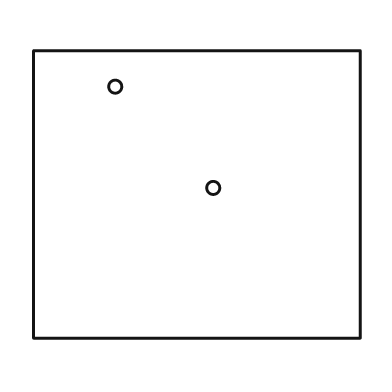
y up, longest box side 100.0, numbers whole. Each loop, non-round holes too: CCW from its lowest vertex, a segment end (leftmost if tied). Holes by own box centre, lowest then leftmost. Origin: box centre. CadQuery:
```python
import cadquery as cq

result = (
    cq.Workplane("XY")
    .moveTo(-50.0, -44.0)
    .lineTo(50.0, -44.0)
    .lineTo(50.0, 44.0)
    .lineTo(-50.0, 44.0)
    .close()
    .moveTo(5.0, 2.0)
    .circle(2.0)
    .moveTo(-25.0, 33.0)
    .circle(2.0)
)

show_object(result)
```